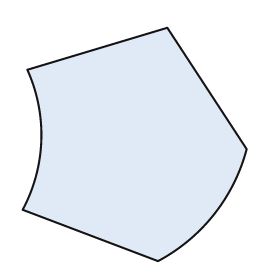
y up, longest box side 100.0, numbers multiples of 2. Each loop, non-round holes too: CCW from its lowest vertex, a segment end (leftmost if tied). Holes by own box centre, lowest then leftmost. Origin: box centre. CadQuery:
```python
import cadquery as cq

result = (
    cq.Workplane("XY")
    .moveTo(10.0, -50.0)
    .threePointArc((34.0, -30.0), (48.0, -2.0))
    .lineTo(14.0, 50.0)
    .lineTo(-46.0, 32.0)
    .threePointArc((-40.0, 2.0), (-48.0, -28.0))
    .close()
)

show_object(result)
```